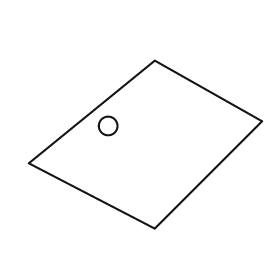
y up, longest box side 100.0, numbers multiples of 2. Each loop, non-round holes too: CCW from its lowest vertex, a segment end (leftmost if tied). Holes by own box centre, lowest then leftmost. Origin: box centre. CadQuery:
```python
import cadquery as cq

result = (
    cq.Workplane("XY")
    .moveTo(4.0, -36.0)
    .lineTo(50.0, 10.0)
    .lineTo(4.0, 36.0)
    .lineTo(-50.0, -8.0)
    .close()
    .moveTo(-16.0, 8.0)
    .circle(4.0)
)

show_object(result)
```